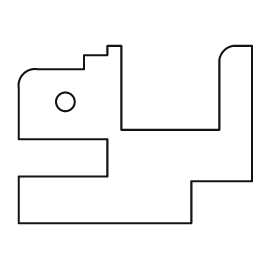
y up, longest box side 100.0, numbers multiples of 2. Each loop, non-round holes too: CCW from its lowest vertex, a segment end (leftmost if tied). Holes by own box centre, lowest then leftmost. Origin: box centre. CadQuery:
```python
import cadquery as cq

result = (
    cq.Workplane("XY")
    .moveTo(-50.0, -38.0)
    .lineTo(24.0, -38.0)
    .lineTo(24.0, -20.0)
    .lineTo(50.0, -20.0)
    .lineTo(50.0, 38.0)
    .lineTo(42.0, 38.0)
    .threePointArc((38.0, 36.0), (36.0, 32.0))
    .lineTo(36.0, 2.0)
    .lineTo(-6.0, 2.0)
    .lineTo(-6.0, 38.0)
    .lineTo(-12.0, 38.0)
    .lineTo(-12.0, 34.0)
    .lineTo(-22.0, 34.0)
    .lineTo(-22.0, 28.0)
    .lineTo(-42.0, 28.0)
    .threePointArc((-48.0, 26.0), (-50.0, 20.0))
    .lineTo(-50.0, -2.0)
    .lineTo(-12.0, -2.0)
    .lineTo(-12.0, -18.0)
    .lineTo(-50.0, -18.0)
    .close()
    .moveTo(-30.0, 14.0)
    .circle(4.0)
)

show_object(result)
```